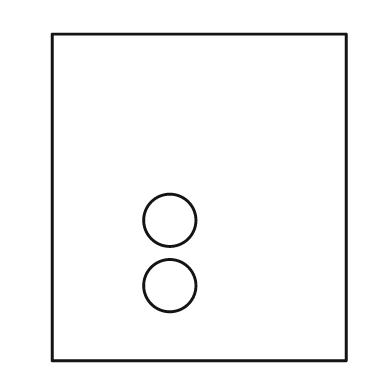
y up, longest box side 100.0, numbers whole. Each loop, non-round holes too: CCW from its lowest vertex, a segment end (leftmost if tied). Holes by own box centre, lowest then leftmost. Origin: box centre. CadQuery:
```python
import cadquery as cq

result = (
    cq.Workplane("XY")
    .moveTo(-45.0, -50.0)
    .lineTo(45.0, -50.0)
    .lineTo(45.0, 50.0)
    .lineTo(-45.0, 50.0)
    .close()
    .moveTo(-9.0, -27.0)
    .circle(8.0)
    .moveTo(-9.0, -7.0)
    .circle(8.0)
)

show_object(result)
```